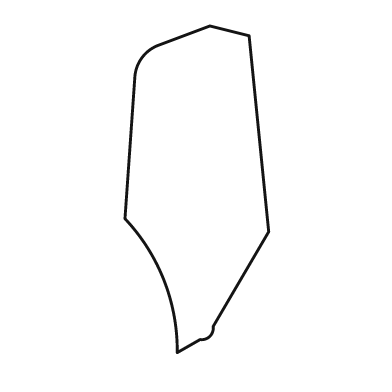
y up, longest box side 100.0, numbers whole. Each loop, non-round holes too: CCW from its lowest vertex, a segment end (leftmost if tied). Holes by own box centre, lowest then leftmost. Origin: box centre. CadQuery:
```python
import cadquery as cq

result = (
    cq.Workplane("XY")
    .moveTo(-6.0, -50.0)
    .lineTo(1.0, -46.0)
    .threePointArc((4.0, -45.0), (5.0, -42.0))
    .lineTo(22.0, -13.0)
    .lineTo(16.0, 47.0)
    .lineTo(4.0, 50.0)
    .lineTo(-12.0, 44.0)
    .threePointArc((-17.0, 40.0), (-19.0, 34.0))
    .lineTo(-22.0, -9.0)
    .threePointArc((-10.0, -28.0), (-6.0, -50.0))
    .close()
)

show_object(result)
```